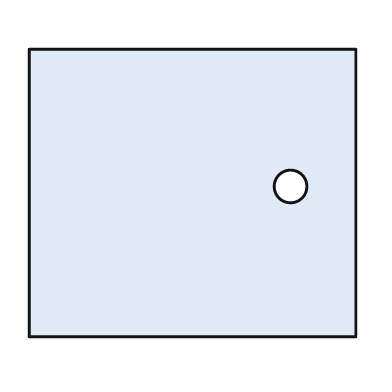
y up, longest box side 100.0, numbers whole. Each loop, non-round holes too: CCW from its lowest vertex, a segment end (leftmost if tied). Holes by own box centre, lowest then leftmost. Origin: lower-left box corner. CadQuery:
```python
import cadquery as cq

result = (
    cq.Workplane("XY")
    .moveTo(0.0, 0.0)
    .lineTo(100.0, 0.0)
    .lineTo(100.0, 88.0)
    .lineTo(0.0, 88.0)
    .close()
    .moveTo(80.0, 46.0)
    .circle(5.0)
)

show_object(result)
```